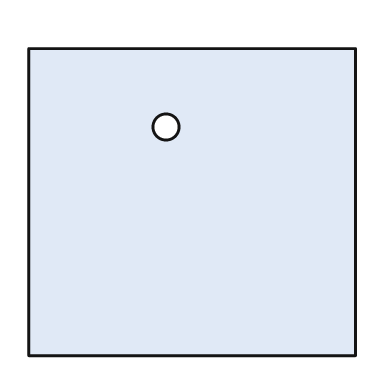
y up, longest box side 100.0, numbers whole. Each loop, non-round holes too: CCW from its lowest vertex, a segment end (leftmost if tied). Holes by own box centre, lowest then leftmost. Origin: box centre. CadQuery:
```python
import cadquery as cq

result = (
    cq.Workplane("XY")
    .moveTo(-50.0, -47.0)
    .lineTo(50.0, -47.0)
    .lineTo(50.0, 47.0)
    .lineTo(-50.0, 47.0)
    .close()
    .moveTo(-8.0, 23.0)
    .circle(4.0)
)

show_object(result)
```